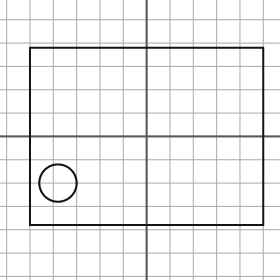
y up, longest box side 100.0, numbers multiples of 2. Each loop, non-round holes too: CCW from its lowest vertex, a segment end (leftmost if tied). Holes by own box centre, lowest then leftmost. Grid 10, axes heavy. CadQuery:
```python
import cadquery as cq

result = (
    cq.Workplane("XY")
    .moveTo(-50.0, -38.0)
    .lineTo(50.0, -38.0)
    .lineTo(50.0, 38.0)
    .lineTo(-50.0, 38.0)
    .close()
    .moveTo(-38.0, -20.0)
    .circle(8.0)
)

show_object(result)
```